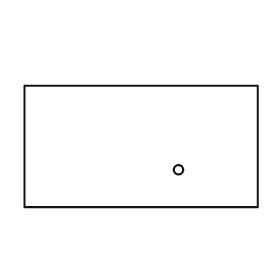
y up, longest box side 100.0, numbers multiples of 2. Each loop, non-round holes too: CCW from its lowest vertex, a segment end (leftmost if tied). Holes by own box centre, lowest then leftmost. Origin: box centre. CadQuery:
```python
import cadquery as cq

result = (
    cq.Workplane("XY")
    .moveTo(-50.0, -26.0)
    .lineTo(50.0, -26.0)
    .lineTo(50.0, 26.0)
    .lineTo(-50.0, 26.0)
    .close()
    .moveTo(16.0, -10.0)
    .circle(2.0)
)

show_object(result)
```